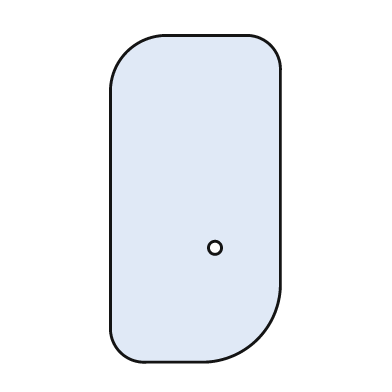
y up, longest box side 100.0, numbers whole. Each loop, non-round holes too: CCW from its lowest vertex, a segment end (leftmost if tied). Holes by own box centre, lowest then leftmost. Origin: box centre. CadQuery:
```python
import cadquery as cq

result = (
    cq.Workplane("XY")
    .moveTo(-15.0, -50.0)
    .lineTo(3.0, -50.0)
    .threePointArc((19.0, -43.0), (26.0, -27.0))
    .lineTo(26.0, 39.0)
    .threePointArc((23.0, 47.0), (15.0, 50.0))
    .lineTo(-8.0, 50.0)
    .threePointArc((-21.0, 45.0), (-26.0, 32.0))
    .lineTo(-26.0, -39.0)
    .threePointArc((-23.0, -47.0), (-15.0, -50.0))
    .close()
    .moveTo(6.0, -15.0)
    .circle(2.0)
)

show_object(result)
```